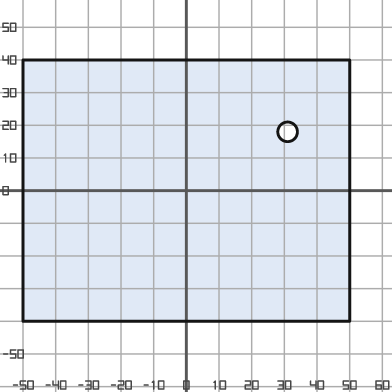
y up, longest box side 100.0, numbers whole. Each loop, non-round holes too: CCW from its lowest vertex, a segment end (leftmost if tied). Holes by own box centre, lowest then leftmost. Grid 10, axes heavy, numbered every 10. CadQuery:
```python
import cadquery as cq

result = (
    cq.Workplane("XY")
    .moveTo(-50.0, -40.0)
    .lineTo(50.0, -40.0)
    .lineTo(50.0, 40.0)
    .lineTo(-50.0, 40.0)
    .close()
    .moveTo(31.0, 18.0)
    .circle(3.0)
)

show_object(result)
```